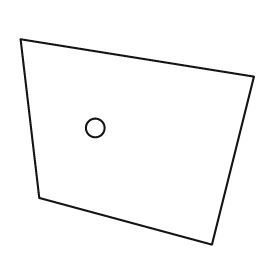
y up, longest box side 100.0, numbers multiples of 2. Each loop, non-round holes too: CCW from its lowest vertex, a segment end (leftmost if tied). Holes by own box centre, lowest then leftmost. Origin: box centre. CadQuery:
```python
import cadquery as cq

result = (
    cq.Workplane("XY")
    .moveTo(32.0, -44.0)
    .lineTo(50.0, 28.0)
    .lineTo(-50.0, 44.0)
    .lineTo(-42.0, -24.0)
    .close()
    .moveTo(-18.0, 6.0)
    .circle(4.0)
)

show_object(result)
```